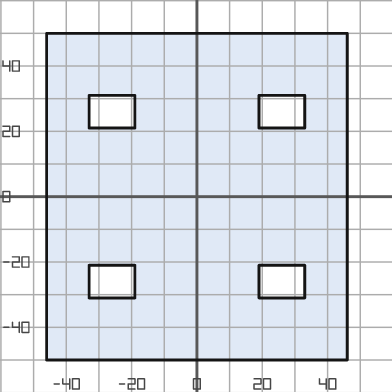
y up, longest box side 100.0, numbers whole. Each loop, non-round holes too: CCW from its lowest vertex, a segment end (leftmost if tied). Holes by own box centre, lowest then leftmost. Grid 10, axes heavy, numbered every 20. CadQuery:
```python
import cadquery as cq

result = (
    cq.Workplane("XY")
    .moveTo(-46.0, -50.0)
    .lineTo(46.0, -50.0)
    .lineTo(46.0, 50.0)
    .lineTo(-46.0, 50.0)
    .close()
    .moveTo(-33.0, -31.0)
    .lineTo(-19.0, -31.0)
    .lineTo(-19.0, -21.0)
    .lineTo(-33.0, -21.0)
    .close()
    .moveTo(19.0, -31.0)
    .lineTo(33.0, -31.0)
    .lineTo(33.0, -21.0)
    .lineTo(19.0, -21.0)
    .close()
    .moveTo(-33.0, 21.0)
    .lineTo(-19.0, 21.0)
    .lineTo(-19.0, 31.0)
    .lineTo(-33.0, 31.0)
    .close()
    .moveTo(19.0, 21.0)
    .lineTo(33.0, 21.0)
    .lineTo(33.0, 31.0)
    .lineTo(19.0, 31.0)
    .close()
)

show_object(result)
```